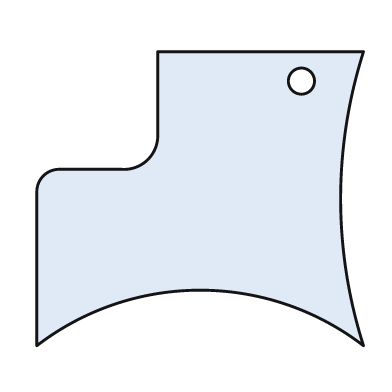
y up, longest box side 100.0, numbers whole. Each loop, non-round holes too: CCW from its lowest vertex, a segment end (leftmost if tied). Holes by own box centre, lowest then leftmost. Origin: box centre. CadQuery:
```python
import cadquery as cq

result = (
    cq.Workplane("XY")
    .moveTo(-50.0, -45.0)
    .threePointArc((0.0, -28.0), (50.0, -45.0))
    .threePointArc((43.0, 0.0), (50.0, 45.0))
    .lineTo(-13.0, 45.0)
    .lineTo(-13.0, 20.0)
    .threePointArc((-16.0, 12.0), (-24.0, 9.0))
    .lineTo(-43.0, 9.0)
    .threePointArc((-48.0, 7.0), (-50.0, 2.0))
    .close()
    .moveTo(31.0, 36.0)
    .circle(4.0)
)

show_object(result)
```